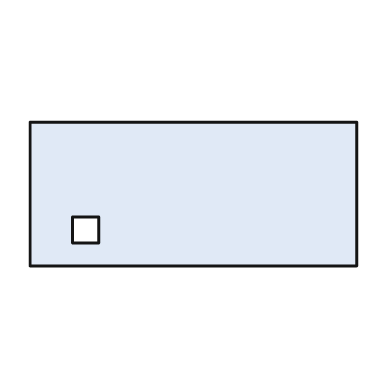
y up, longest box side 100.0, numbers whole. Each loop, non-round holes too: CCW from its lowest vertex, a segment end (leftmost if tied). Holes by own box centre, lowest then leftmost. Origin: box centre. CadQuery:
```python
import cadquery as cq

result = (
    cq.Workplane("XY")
    .moveTo(-50.0, -22.0)
    .lineTo(50.0, -22.0)
    .lineTo(50.0, 22.0)
    .lineTo(-50.0, 22.0)
    .close()
    .moveTo(-37.0, -15.0)
    .lineTo(-29.0, -15.0)
    .lineTo(-29.0, -7.0)
    .lineTo(-37.0, -7.0)
    .close()
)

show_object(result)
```